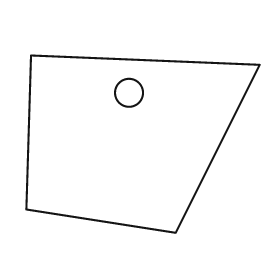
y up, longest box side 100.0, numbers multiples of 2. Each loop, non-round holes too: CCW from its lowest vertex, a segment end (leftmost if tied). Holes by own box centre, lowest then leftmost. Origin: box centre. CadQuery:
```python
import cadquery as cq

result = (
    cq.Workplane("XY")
    .moveTo(14.0, -38.0)
    .lineTo(50.0, 34.0)
    .lineTo(-48.0, 38.0)
    .lineTo(-50.0, -28.0)
    .close()
    .moveTo(-6.0, 22.0)
    .circle(6.0)
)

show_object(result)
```